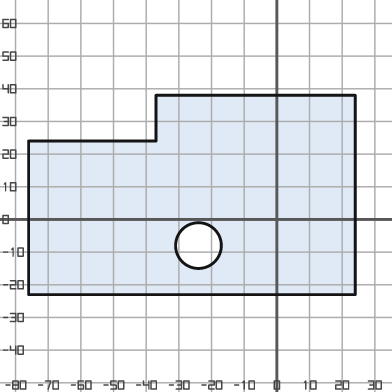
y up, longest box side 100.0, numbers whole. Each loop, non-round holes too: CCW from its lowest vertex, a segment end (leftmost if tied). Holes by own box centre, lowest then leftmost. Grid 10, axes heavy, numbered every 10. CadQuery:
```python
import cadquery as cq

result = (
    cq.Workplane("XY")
    .moveTo(-76.0, -23.0)
    .lineTo(24.0, -23.0)
    .lineTo(24.0, 38.0)
    .lineTo(-37.0, 38.0)
    .lineTo(-37.0, 24.0)
    .lineTo(-76.0, 24.0)
    .close()
    .moveTo(-24.0, -8.0)
    .circle(7.0)
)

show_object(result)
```